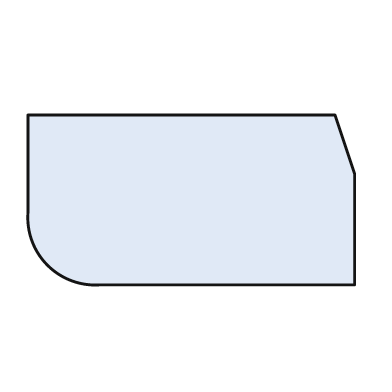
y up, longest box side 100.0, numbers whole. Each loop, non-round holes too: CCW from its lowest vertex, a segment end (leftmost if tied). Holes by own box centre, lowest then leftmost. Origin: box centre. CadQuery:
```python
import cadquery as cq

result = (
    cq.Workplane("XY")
    .moveTo(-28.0, -26.0)
    .lineTo(50.0, -26.0)
    .lineTo(50.0, 8.0)
    .lineTo(44.0, 26.0)
    .lineTo(-50.0, 26.0)
    .lineTo(-50.0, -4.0)
    .threePointArc((-44.0, -20.0), (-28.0, -26.0))
    .close()
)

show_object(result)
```